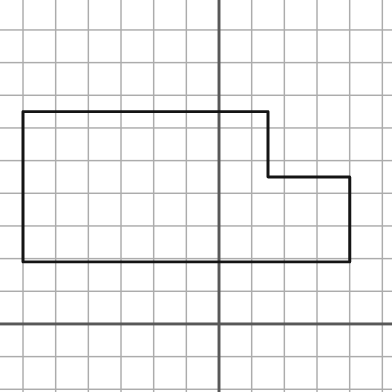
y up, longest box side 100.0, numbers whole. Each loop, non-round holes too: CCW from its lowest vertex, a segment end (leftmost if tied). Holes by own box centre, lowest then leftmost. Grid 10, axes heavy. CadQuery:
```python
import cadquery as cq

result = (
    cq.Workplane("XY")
    .moveTo(-60.0, 19.0)
    .lineTo(40.0, 19.0)
    .lineTo(40.0, 45.0)
    .lineTo(15.0, 45.0)
    .lineTo(15.0, 65.0)
    .lineTo(-60.0, 65.0)
    .close()
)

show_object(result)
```